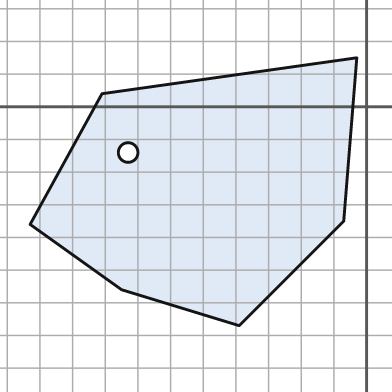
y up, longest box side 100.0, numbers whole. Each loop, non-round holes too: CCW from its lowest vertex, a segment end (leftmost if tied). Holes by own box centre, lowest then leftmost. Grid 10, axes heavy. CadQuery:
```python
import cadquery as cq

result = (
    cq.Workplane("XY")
    .moveTo(-39.0, -67.0)
    .lineTo(-7.0, -35.0)
    .lineTo(-3.0, 15.0)
    .lineTo(-81.0, 4.0)
    .lineTo(-103.0, -36.0)
    .lineTo(-75.0, -56.0)
    .close()
    .moveTo(-73.0, -14.0)
    .circle(3.0)
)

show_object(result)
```